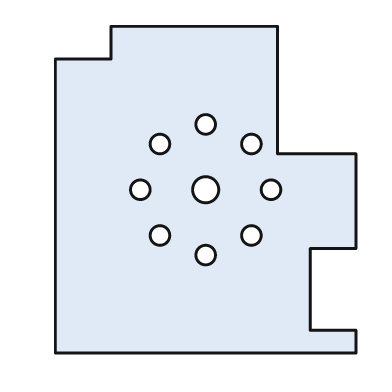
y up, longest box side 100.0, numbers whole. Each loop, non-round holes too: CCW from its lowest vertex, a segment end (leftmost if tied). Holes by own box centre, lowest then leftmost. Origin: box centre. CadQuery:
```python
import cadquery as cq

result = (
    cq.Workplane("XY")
    .moveTo(-46.0, -50.0)
    .lineTo(46.0, -50.0)
    .lineTo(46.0, -43.0)
    .lineTo(32.0, -43.0)
    .lineTo(32.0, -18.0)
    .lineTo(46.0, -18.0)
    .lineTo(46.0, 11.0)
    .lineTo(22.0, 11.0)
    .lineTo(22.0, 50.0)
    .lineTo(-29.0, 50.0)
    .lineTo(-29.0, 40.0)
    .lineTo(-46.0, 40.0)
    .close()
    .moveTo(0.0, -20.0)
    .circle(3.0)
    .moveTo(-14.0, -14.0)
    .circle(3.0)
    .moveTo(14.0, -14.0)
    .circle(3.0)
    .moveTo(-20.0, 0.0)
    .circle(3.0)
    .moveTo(0.0, 0.0)
    .circle(4.0)
    .moveTo(20.0, 0.0)
    .circle(3.0)
    .moveTo(-14.0, 14.0)
    .circle(3.0)
    .moveTo(14.0, 14.0)
    .circle(3.0)
    .moveTo(0.0, 20.0)
    .circle(3.0)
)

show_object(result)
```